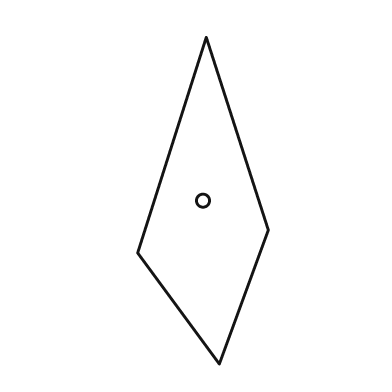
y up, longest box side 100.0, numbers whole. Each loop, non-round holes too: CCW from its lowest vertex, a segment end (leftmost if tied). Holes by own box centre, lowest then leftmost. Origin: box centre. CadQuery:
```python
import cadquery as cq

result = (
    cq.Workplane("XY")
    .moveTo(5.0, -50.0)
    .lineTo(20.0, -9.0)
    .lineTo(1.0, 50.0)
    .lineTo(-20.0, -16.0)
    .close()
    .moveTo(0.0, 0.0)
    .circle(2.0)
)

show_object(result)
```